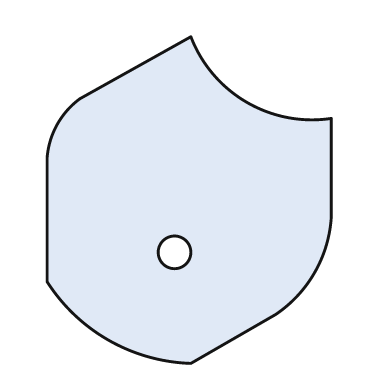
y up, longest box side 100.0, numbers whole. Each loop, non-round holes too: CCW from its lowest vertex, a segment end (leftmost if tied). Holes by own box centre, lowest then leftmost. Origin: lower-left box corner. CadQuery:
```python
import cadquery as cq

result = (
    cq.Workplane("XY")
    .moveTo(44.0, 0.0)
    .lineTo(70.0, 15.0)
    .threePointArc((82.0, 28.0), (87.0, 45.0))
    .lineTo(87.0, 75.0)
    .threePointArc((61.0, 80.0), (44.0, 100.0))
    .lineTo(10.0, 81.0)
    .threePointArc((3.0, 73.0), (0.0, 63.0))
    .lineTo(0.0, 25.0)
    .threePointArc((19.0, 7.0), (44.0, 0.0))
    .close()
    .moveTo(39.0, 34.0)
    .circle(5.0)
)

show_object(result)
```